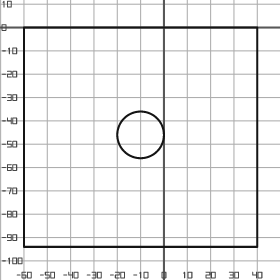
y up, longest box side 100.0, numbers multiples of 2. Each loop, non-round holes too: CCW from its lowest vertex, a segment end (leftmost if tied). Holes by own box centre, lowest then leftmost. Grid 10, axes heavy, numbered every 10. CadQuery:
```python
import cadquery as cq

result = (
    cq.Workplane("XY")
    .moveTo(-60.0, -94.0)
    .lineTo(40.0, -94.0)
    .lineTo(40.0, 0.0)
    .lineTo(-60.0, 0.0)
    .close()
    .moveTo(-10.0, -46.0)
    .circle(10.0)
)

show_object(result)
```